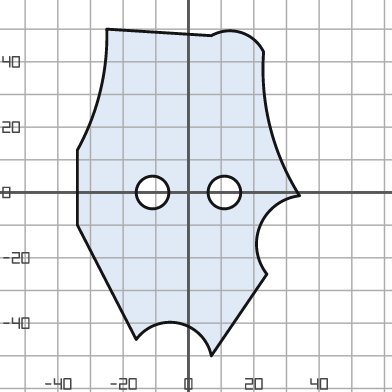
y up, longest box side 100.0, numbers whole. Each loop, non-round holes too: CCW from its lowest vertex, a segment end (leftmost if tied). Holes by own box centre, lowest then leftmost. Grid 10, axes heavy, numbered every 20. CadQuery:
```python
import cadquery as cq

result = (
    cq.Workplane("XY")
    .moveTo(7.0, -50.0)
    .lineTo(24.0, -25.0)
    .threePointArc((22.0, -10.0), (34.0, -1.0))
    .threePointArc((25.0, 20.0), (23.0, 43.0))
    .threePointArc((16.0, 49.0), (7.0, 48.0))
    .lineTo(-25.0, 50.0)
    .threePointArc((-27.0, 31.0), (-34.0, 13.0))
    .lineTo(-34.0, -10.0)
    .lineTo(-16.0, -45.0)
    .threePointArc((-3.0, -40.0), (7.0, -50.0))
    .close()
    .moveTo(-11.0, 0.0)
    .circle(5.0)
    .moveTo(11.0, 0.0)
    .circle(5.0)
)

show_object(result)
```